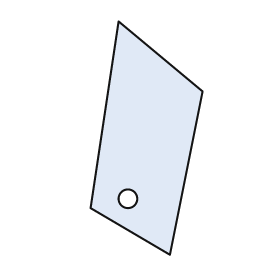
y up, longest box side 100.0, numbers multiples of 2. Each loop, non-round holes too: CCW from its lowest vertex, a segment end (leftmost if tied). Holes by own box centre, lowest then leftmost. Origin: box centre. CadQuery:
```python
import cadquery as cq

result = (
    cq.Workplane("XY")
    .moveTo(10.0, -50.0)
    .lineTo(24.0, 20.0)
    .lineTo(-12.0, 50.0)
    .lineTo(-24.0, -30.0)
    .close()
    .moveTo(-8.0, -26.0)
    .circle(4.0)
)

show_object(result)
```